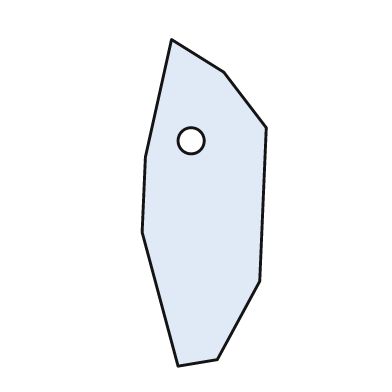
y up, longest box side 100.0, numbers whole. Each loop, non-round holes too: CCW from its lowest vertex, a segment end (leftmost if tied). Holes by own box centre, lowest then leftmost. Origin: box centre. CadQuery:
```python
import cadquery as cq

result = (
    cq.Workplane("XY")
    .moveTo(-8.0, -50.0)
    .lineTo(4.0, -48.0)
    .lineTo(17.0, -24.0)
    .lineTo(19.0, 23.0)
    .lineTo(6.0, 40.0)
    .lineTo(-10.0, 50.0)
    .lineTo(-18.0, 14.0)
    .lineTo(-19.0, -9.0)
    .close()
    .moveTo(-4.0, 19.0)
    .circle(4.0)
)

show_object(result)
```